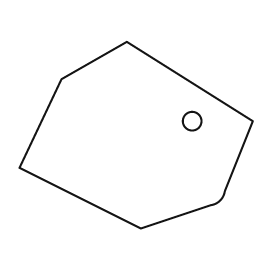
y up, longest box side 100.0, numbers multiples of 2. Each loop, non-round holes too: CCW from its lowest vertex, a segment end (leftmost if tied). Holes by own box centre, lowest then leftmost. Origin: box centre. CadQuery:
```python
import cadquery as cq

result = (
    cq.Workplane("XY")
    .moveTo(2.0, -40.0)
    .lineTo(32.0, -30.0)
    .threePointArc((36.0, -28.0), (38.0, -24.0))
    .lineTo(50.0, 6.0)
    .lineTo(-4.0, 40.0)
    .lineTo(-32.0, 24.0)
    .lineTo(-50.0, -14.0)
    .close()
    .moveTo(24.0, 6.0)
    .circle(4.0)
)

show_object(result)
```